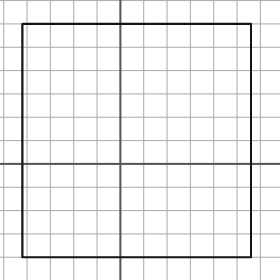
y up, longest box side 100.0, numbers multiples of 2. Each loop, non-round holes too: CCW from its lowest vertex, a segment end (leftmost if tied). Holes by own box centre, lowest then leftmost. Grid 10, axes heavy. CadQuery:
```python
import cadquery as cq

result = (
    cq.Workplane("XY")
    .moveTo(-42.0, -40.0)
    .lineTo(56.0, -40.0)
    .lineTo(56.0, 60.0)
    .lineTo(-42.0, 60.0)
    .close()
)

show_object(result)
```